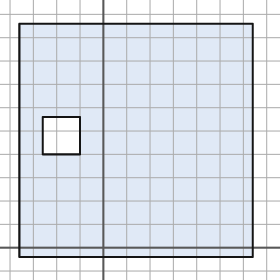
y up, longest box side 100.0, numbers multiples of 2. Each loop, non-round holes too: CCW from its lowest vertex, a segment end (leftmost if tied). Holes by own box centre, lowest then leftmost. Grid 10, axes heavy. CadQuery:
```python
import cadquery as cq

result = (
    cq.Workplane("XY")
    .moveTo(-36.0, -4.0)
    .lineTo(64.0, -4.0)
    .lineTo(64.0, 96.0)
    .lineTo(-36.0, 96.0)
    .close()
    .moveTo(-26.0, 40.0)
    .lineTo(-10.0, 40.0)
    .lineTo(-10.0, 56.0)
    .lineTo(-26.0, 56.0)
    .close()
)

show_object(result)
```